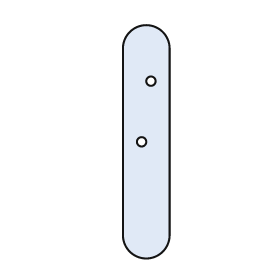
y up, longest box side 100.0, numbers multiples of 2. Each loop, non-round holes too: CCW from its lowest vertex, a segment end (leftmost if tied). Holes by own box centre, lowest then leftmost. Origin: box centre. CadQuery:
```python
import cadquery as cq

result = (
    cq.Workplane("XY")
    .moveTo(-10.0, -40.0)
    .threePointArc((0.0, -50.0), (10.0, -40.0))
    .lineTo(10.0, 40.0)
    .threePointArc((0.0, 50.0), (-10.0, 40.0))
    .close()
    .moveTo(-2.0, 0.0)
    .circle(2.0)
    .moveTo(2.0, 26.0)
    .circle(2.0)
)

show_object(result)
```